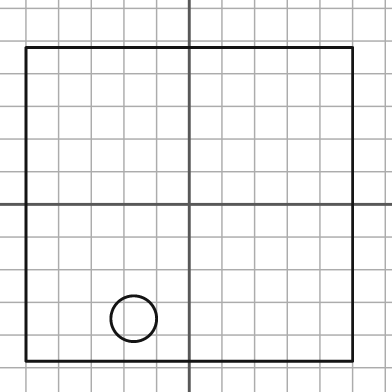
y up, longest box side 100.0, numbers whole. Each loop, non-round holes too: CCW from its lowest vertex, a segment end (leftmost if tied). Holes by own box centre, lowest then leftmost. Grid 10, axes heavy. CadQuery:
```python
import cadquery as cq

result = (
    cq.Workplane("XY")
    .moveTo(-50.0, -48.0)
    .lineTo(50.0, -48.0)
    .lineTo(50.0, 48.0)
    .lineTo(-50.0, 48.0)
    .close()
    .moveTo(-17.0, -35.0)
    .circle(7.0)
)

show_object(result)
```